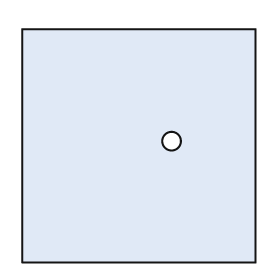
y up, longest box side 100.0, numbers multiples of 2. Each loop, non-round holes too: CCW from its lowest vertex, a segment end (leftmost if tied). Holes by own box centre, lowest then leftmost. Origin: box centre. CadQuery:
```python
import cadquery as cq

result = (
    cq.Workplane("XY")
    .moveTo(-50.0, -50.0)
    .lineTo(50.0, -50.0)
    .lineTo(50.0, 50.0)
    .lineTo(-50.0, 50.0)
    .close()
    .moveTo(14.0, 2.0)
    .circle(4.0)
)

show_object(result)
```